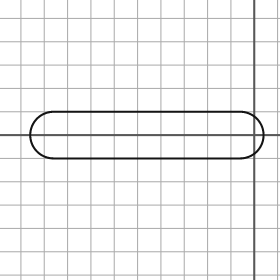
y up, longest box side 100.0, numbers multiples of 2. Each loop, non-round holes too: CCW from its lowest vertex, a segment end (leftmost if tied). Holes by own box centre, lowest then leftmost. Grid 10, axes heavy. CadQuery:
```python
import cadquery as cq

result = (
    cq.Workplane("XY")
    .moveTo(-86.0, -10.0)
    .lineTo(-6.0, -10.0)
    .threePointArc((4.0, 0.0), (-6.0, 10.0))
    .lineTo(-86.0, 10.0)
    .threePointArc((-96.0, 0.0), (-86.0, -10.0))
    .close()
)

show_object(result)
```